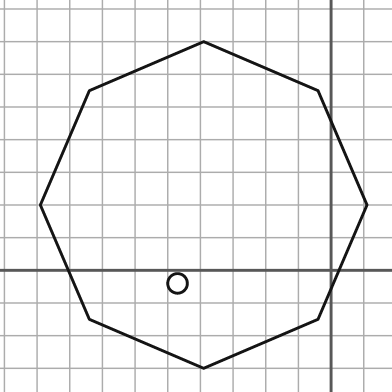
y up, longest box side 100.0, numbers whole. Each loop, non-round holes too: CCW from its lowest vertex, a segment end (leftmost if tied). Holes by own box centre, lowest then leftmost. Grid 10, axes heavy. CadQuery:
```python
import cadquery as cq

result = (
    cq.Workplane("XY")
    .moveTo(-39.0, -30.0)
    .lineTo(-4.0, -15.0)
    .lineTo(11.0, 20.0)
    .lineTo(-4.0, 55.0)
    .lineTo(-39.0, 70.0)
    .lineTo(-74.0, 55.0)
    .lineTo(-89.0, 20.0)
    .lineTo(-74.0, -15.0)
    .close()
    .moveTo(-47.0, -4.0)
    .circle(3.0)
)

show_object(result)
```